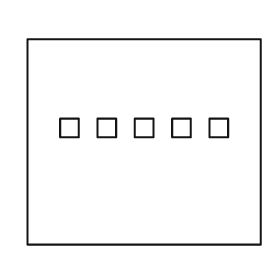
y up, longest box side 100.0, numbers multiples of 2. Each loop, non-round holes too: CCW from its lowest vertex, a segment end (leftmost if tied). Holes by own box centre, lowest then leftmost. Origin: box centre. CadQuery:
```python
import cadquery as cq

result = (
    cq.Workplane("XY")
    .moveTo(-50.0, -44.0)
    .lineTo(50.0, -44.0)
    .lineTo(50.0, 44.0)
    .lineTo(-50.0, 44.0)
    .close()
    .moveTo(-36.0, 2.0)
    .lineTo(-28.0, 2.0)
    .lineTo(-28.0, 10.0)
    .lineTo(-36.0, 10.0)
    .close()
    .moveTo(-20.0, 2.0)
    .lineTo(-12.0, 2.0)
    .lineTo(-12.0, 10.0)
    .lineTo(-20.0, 10.0)
    .close()
    .moveTo(-4.0, 2.0)
    .lineTo(4.0, 2.0)
    .lineTo(4.0, 10.0)
    .lineTo(-4.0, 10.0)
    .close()
    .moveTo(12.0, 2.0)
    .lineTo(20.0, 2.0)
    .lineTo(20.0, 10.0)
    .lineTo(12.0, 10.0)
    .close()
    .moveTo(28.0, 2.0)
    .lineTo(36.0, 2.0)
    .lineTo(36.0, 10.0)
    .lineTo(28.0, 10.0)
    .close()
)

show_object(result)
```